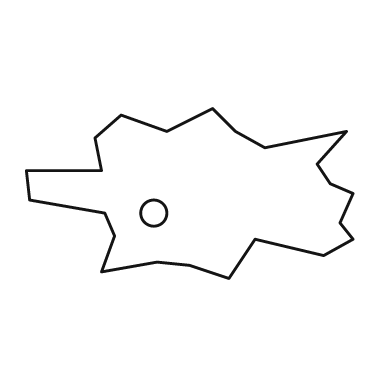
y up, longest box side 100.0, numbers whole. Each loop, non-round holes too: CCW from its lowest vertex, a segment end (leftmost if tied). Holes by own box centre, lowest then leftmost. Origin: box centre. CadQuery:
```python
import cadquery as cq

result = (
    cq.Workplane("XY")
    .moveTo(12.0, -26.0)
    .lineTo(20.0, -14.0)
    .lineTo(41.0, -19.0)
    .lineTo(50.0, -14.0)
    .lineTo(46.0, -9.0)
    .lineTo(50.0, 0.0)
    .lineTo(43.0, 3.0)
    .lineTo(39.0, 9.0)
    .lineTo(48.0, 19.0)
    .lineTo(23.0, 14.0)
    .lineTo(14.0, 19.0)
    .lineTo(7.0, 26.0)
    .lineTo(-7.0, 19.0)
    .lineTo(-21.0, 24.0)
    .lineTo(-29.0, 17.0)
    .lineTo(-27.0, 7.0)
    .lineTo(-50.0, 7.0)
    .lineTo(-49.0, -2.0)
    .lineTo(-26.0, -6.0)
    .lineTo(-23.0, -13.0)
    .lineTo(-27.0, -24.0)
    .lineTo(-10.0, -21.0)
    .lineTo(0.0, -22.0)
    .close()
    .moveTo(-11.0, -6.0)
    .circle(4.0)
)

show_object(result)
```